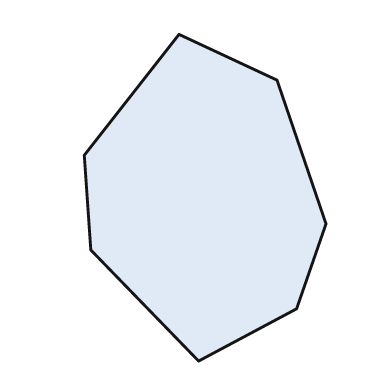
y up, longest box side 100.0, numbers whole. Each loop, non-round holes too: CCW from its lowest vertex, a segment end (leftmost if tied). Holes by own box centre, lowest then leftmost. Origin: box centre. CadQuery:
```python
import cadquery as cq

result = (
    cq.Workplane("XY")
    .moveTo(-2.0, -50.0)
    .lineTo(28.0, -34.0)
    .lineTo(37.0, -8.0)
    .lineTo(22.0, 36.0)
    .lineTo(-8.0, 50.0)
    .lineTo(-37.0, 13.0)
    .lineTo(-35.0, -16.0)
    .close()
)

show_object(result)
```